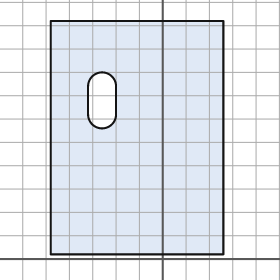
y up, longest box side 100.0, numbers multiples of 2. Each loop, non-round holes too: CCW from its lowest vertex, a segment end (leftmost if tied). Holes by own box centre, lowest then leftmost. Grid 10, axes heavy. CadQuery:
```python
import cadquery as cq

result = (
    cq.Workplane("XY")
    .moveTo(-48.0, 2.0)
    .lineTo(26.0, 2.0)
    .lineTo(26.0, 102.0)
    .lineTo(-48.0, 102.0)
    .close()
    .moveTo(-32.0, 62.0)
    .threePointArc((-26.0, 56.0), (-20.0, 62.0))
    .lineTo(-20.0, 74.0)
    .threePointArc((-26.0, 80.0), (-32.0, 74.0))
    .close()
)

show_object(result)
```